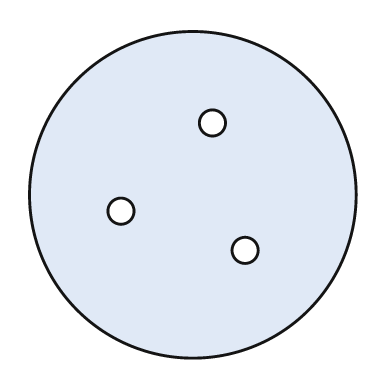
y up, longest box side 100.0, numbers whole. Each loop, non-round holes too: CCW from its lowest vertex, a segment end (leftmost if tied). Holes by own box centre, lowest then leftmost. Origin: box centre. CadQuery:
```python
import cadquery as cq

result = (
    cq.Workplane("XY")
    .moveTo(0.0, 0.0)
    .circle(50.0)
    .moveTo(16.0, -17.0)
    .circle(4.0)
    .moveTo(-22.0, -5.0)
    .circle(4.0)
    .moveTo(6.0, 22.0)
    .circle(4.0)
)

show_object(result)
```